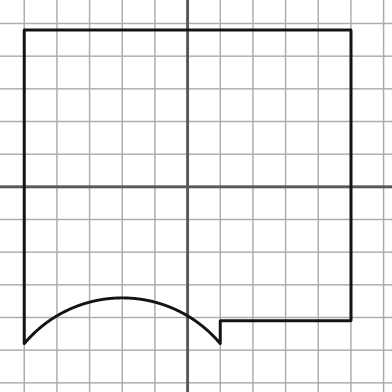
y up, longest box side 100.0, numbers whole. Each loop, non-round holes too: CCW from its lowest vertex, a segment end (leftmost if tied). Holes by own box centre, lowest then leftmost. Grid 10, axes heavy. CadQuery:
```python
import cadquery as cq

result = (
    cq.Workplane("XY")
    .moveTo(-50.0, -48.0)
    .threePointArc((-20.0, -34.0), (10.0, -48.0))
    .lineTo(10.0, -41.0)
    .lineTo(50.0, -41.0)
    .lineTo(50.0, 48.0)
    .lineTo(-50.0, 48.0)
    .close()
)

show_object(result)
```